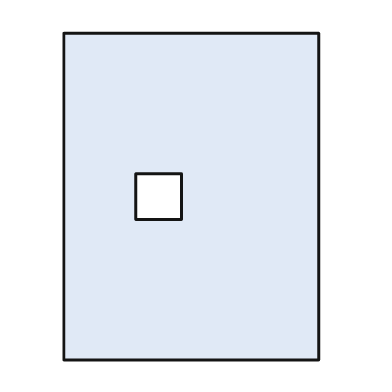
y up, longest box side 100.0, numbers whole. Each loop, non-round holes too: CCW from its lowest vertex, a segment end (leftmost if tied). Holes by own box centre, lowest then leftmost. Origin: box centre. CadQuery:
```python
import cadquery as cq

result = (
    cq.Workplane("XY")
    .moveTo(-39.0, -50.0)
    .lineTo(39.0, -50.0)
    .lineTo(39.0, 50.0)
    .lineTo(-39.0, 50.0)
    .close()
    .moveTo(-17.0, -7.0)
    .lineTo(-3.0, -7.0)
    .lineTo(-3.0, 7.0)
    .lineTo(-17.0, 7.0)
    .close()
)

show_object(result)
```